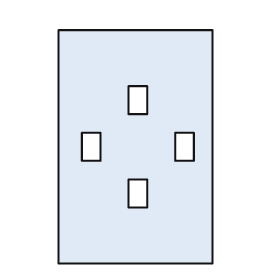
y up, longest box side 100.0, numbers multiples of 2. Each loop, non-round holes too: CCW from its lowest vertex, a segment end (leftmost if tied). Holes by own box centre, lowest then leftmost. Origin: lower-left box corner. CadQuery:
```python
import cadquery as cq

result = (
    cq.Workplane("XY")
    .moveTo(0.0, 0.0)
    .lineTo(66.0, 0.0)
    .lineTo(66.0, 100.0)
    .lineTo(0.0, 100.0)
    .close()
    .moveTo(30.0, 24.0)
    .lineTo(38.0, 24.0)
    .lineTo(38.0, 36.0)
    .lineTo(30.0, 36.0)
    .close()
    .moveTo(10.0, 44.0)
    .lineTo(18.0, 44.0)
    .lineTo(18.0, 56.0)
    .lineTo(10.0, 56.0)
    .close()
    .moveTo(50.0, 44.0)
    .lineTo(58.0, 44.0)
    .lineTo(58.0, 56.0)
    .lineTo(50.0, 56.0)
    .close()
    .moveTo(30.0, 64.0)
    .lineTo(38.0, 64.0)
    .lineTo(38.0, 76.0)
    .lineTo(30.0, 76.0)
    .close()
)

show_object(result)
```